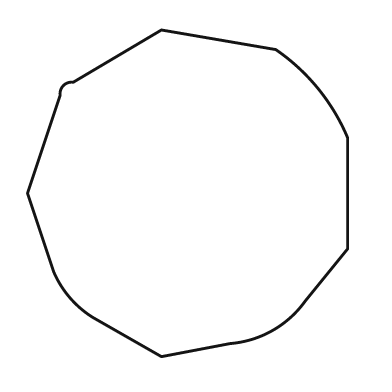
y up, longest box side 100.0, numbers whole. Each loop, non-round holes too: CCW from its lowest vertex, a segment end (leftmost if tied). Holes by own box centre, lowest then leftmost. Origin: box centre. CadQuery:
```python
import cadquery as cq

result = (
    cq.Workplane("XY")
    .moveTo(-8.0, -50.0)
    .lineTo(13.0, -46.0)
    .threePointArc((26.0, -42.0), (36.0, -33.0))
    .lineTo(49.0, -17.0)
    .lineTo(49.0, 17.0)
    .threePointArc((40.0, 32.0), (27.0, 44.0))
    .lineTo(-8.0, 50.0)
    .lineTo(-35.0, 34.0)
    .threePointArc((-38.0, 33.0), (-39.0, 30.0))
    .lineTo(-49.0, 0.0)
    .lineTo(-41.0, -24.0)
    .threePointArc((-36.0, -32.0), (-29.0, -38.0))
    .close()
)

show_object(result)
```